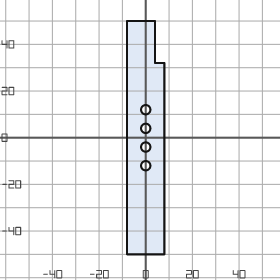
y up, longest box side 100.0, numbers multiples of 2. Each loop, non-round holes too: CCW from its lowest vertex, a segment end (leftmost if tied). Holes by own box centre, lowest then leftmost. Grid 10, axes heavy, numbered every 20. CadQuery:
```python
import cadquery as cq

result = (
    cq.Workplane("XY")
    .moveTo(-8.0, -50.0)
    .lineTo(8.0, -50.0)
    .lineTo(8.0, 32.0)
    .lineTo(4.0, 32.0)
    .lineTo(4.0, 50.0)
    .lineTo(-8.0, 50.0)
    .close()
    .moveTo(0.0, -12.0)
    .circle(2.0)
    .moveTo(0.0, -4.0)
    .circle(2.0)
    .moveTo(0.0, 4.0)
    .circle(2.0)
    .moveTo(0.0, 12.0)
    .circle(2.0)
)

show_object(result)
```